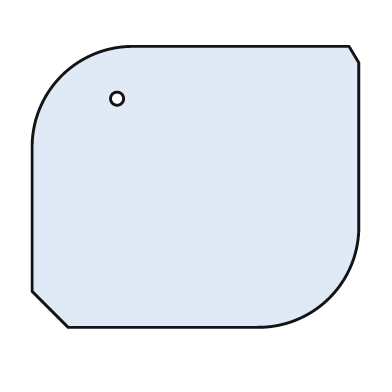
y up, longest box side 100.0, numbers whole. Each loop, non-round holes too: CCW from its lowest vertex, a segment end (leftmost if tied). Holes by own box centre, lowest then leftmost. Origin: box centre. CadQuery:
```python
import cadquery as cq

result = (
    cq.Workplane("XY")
    .moveTo(-39.0, -43.0)
    .lineTo(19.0, -43.0)
    .threePointArc((41.0, -34.0), (50.0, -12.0))
    .lineTo(50.0, 38.0)
    .lineTo(47.0, 43.0)
    .lineTo(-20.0, 43.0)
    .threePointArc((-41.0, 34.0), (-50.0, 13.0))
    .lineTo(-50.0, -32.0)
    .close()
    .moveTo(-24.0, 27.0)
    .circle(2.0)
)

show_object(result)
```